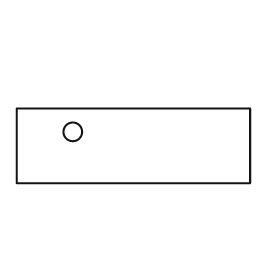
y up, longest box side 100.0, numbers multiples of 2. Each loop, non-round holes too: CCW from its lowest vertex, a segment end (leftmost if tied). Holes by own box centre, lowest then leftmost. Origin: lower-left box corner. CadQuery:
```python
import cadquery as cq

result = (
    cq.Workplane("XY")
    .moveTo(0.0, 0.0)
    .lineTo(100.0, 0.0)
    .lineTo(100.0, 32.0)
    .lineTo(0.0, 32.0)
    .close()
    .moveTo(24.0, 22.0)
    .circle(4.0)
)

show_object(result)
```